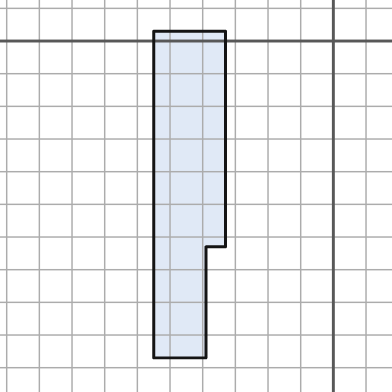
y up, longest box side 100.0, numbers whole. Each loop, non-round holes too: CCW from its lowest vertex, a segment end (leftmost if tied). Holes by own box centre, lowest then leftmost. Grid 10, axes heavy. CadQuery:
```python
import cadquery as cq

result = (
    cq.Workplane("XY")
    .moveTo(-55.0, -97.0)
    .lineTo(-39.0, -97.0)
    .lineTo(-39.0, -63.0)
    .lineTo(-33.0, -63.0)
    .lineTo(-33.0, 3.0)
    .lineTo(-55.0, 3.0)
    .close()
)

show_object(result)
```